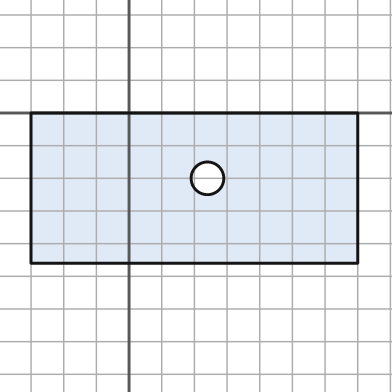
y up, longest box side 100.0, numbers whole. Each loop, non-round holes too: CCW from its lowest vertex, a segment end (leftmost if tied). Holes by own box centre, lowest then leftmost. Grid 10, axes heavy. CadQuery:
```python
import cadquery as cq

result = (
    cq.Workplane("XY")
    .moveTo(-30.0, -46.0)
    .lineTo(70.0, -46.0)
    .lineTo(70.0, 0.0)
    .lineTo(-30.0, 0.0)
    .close()
    .moveTo(24.0, -20.0)
    .circle(5.0)
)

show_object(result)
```